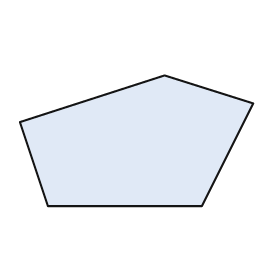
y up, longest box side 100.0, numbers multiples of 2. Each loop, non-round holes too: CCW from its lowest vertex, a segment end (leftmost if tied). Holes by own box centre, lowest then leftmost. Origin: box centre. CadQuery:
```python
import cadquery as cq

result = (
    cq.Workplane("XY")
    .moveTo(-38.0, -28.0)
    .lineTo(28.0, -28.0)
    .lineTo(50.0, 16.0)
    .lineTo(12.0, 28.0)
    .lineTo(-50.0, 8.0)
    .close()
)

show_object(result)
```